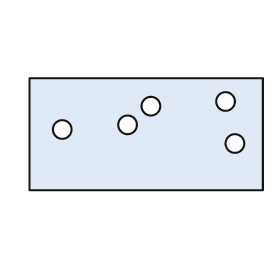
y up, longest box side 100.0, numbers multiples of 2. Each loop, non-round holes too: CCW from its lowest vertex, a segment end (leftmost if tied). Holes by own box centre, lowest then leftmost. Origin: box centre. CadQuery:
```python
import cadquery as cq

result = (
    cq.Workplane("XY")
    .moveTo(-50.0, -24.0)
    .lineTo(50.0, -24.0)
    .lineTo(50.0, 24.0)
    .lineTo(-50.0, 24.0)
    .close()
    .moveTo(38.0, -4.0)
    .circle(4.0)
    .moveTo(-36.0, 2.0)
    .circle(4.0)
    .moveTo(-8.0, 4.0)
    .circle(4.0)
    .moveTo(2.0, 12.0)
    .circle(4.0)
    .moveTo(34.0, 14.0)
    .circle(4.0)
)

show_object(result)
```